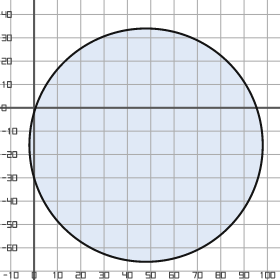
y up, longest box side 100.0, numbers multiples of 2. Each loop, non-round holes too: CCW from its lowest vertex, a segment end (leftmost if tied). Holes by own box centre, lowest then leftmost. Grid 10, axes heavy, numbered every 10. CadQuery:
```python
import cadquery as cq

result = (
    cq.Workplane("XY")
    .moveTo(48.0, -16.0)
    .circle(50.0)
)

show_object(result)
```